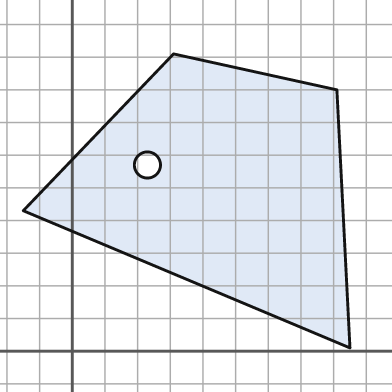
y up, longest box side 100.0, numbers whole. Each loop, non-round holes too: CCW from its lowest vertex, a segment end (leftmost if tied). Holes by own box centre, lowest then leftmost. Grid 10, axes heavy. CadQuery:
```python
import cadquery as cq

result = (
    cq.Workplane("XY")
    .moveTo(85.0, 1.0)
    .lineTo(81.0, 80.0)
    .lineTo(31.0, 91.0)
    .lineTo(-15.0, 43.0)
    .close()
    .moveTo(23.0, 57.0)
    .circle(4.0)
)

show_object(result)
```